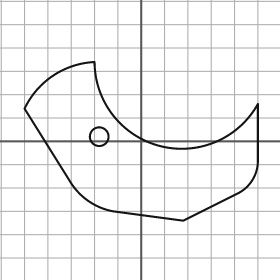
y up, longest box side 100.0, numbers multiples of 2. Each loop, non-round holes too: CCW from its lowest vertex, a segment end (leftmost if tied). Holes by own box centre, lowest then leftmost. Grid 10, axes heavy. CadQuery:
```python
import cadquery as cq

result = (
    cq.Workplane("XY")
    .moveTo(18.0, -34.0)
    .lineTo(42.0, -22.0)
    .threePointArc((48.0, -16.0), (50.0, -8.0))
    .lineTo(50.0, 16.0)
    .threePointArc((8.0, -2.0), (-20.0, 34.0))
    .threePointArc((-38.0, 28.0), (-50.0, 14.0))
    .lineTo(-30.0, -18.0)
    .threePointArc((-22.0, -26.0), (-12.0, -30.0))
    .close()
    .moveTo(-18.0, 2.0)
    .circle(4.0)
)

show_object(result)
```